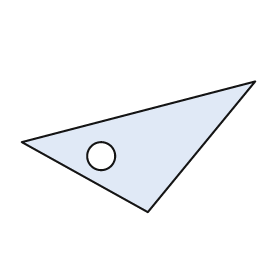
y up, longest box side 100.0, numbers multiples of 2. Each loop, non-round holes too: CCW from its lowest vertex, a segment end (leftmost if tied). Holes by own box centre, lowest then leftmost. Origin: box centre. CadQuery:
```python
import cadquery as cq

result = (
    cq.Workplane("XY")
    .moveTo(4.0, -28.0)
    .lineTo(50.0, 28.0)
    .lineTo(-50.0, 2.0)
    .close()
    .moveTo(-16.0, -4.0)
    .circle(6.0)
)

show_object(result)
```